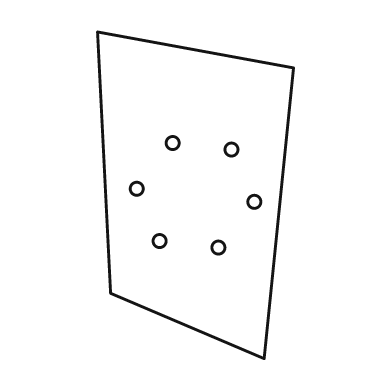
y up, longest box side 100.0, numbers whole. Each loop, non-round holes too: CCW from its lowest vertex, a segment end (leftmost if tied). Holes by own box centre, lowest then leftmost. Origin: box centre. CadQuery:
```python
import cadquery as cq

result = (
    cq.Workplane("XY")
    .moveTo(21.0, -50.0)
    .lineTo(30.0, 39.0)
    .lineTo(-30.0, 50.0)
    .lineTo(-26.0, -30.0)
    .close()
    .moveTo(7.0, -16.0)
    .circle(2.0)
    .moveTo(-11.0, -14.0)
    .circle(2.0)
    .moveTo(18.0, -2.0)
    .circle(2.0)
    .moveTo(-18.0, 2.0)
    .circle(2.0)
    .moveTo(11.0, 14.0)
    .circle(2.0)
    .moveTo(-7.0, 16.0)
    .circle(2.0)
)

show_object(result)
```